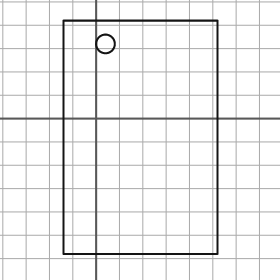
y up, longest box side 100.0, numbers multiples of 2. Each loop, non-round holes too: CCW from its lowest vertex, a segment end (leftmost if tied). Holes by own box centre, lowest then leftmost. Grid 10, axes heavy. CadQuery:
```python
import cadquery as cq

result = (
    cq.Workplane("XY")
    .moveTo(-14.0, -58.0)
    .lineTo(52.0, -58.0)
    .lineTo(52.0, 42.0)
    .lineTo(-14.0, 42.0)
    .close()
    .moveTo(4.0, 32.0)
    .circle(4.0)
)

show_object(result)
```